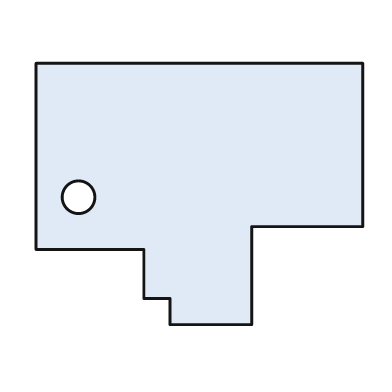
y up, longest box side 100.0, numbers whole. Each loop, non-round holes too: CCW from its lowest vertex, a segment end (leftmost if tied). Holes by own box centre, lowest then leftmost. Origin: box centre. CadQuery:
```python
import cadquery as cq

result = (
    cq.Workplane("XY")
    .moveTo(-9.0, -40.0)
    .lineTo(16.0, -40.0)
    .lineTo(16.0, -10.0)
    .lineTo(50.0, -10.0)
    .lineTo(50.0, 40.0)
    .lineTo(-50.0, 40.0)
    .lineTo(-50.0, -17.0)
    .lineTo(-17.0, -17.0)
    .lineTo(-17.0, -32.0)
    .lineTo(-9.0, -32.0)
    .close()
    .moveTo(-37.0, -1.0)
    .circle(5.0)
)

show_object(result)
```